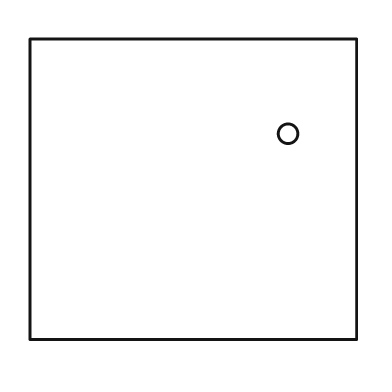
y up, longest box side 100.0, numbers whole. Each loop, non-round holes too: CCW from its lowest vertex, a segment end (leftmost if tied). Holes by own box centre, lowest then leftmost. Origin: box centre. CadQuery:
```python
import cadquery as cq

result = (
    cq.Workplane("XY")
    .moveTo(-50.0, -46.0)
    .lineTo(50.0, -46.0)
    .lineTo(50.0, 46.0)
    .lineTo(-50.0, 46.0)
    .close()
    .moveTo(29.0, 17.0)
    .circle(3.0)
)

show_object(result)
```